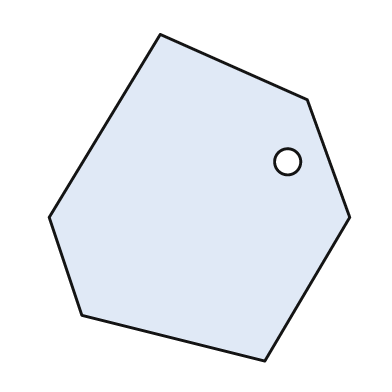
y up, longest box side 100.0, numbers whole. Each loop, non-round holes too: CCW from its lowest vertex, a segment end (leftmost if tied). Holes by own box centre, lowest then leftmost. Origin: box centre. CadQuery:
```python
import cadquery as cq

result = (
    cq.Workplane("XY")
    .moveTo(20.0, -50.0)
    .lineTo(46.0, -6.0)
    .lineTo(33.0, 30.0)
    .lineTo(-12.0, 50.0)
    .lineTo(-46.0, -6.0)
    .lineTo(-36.0, -36.0)
    .close()
    .moveTo(27.0, 11.0)
    .circle(4.0)
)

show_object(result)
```